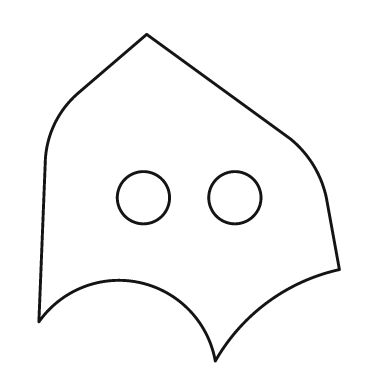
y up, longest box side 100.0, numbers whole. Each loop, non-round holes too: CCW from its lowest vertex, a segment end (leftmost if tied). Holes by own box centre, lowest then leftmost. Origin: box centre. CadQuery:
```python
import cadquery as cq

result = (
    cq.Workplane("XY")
    .moveTo(8.0, -50.0)
    .threePointArc((24.0, -32.0), (46.0, -22.0))
    .lineTo(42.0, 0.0)
    .threePointArc((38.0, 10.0), (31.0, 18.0))
    .lineTo(-13.0, 50.0)
    .lineTo(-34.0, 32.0)
    .threePointArc((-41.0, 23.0), (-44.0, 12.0))
    .lineTo(-46.0, -38.0)
    .threePointArc((-15.0, -26.0), (8.0, -50.0))
    .close()
    .moveTo(-14.0, 0.0)
    .circle(8.0)
    .moveTo(14.0, 0.0)
    .circle(8.0)
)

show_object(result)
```